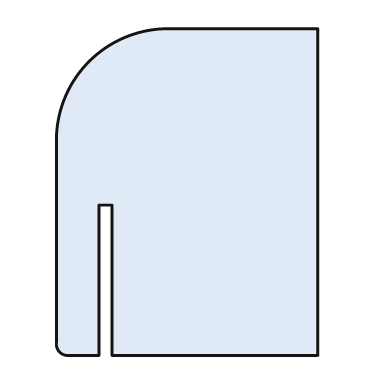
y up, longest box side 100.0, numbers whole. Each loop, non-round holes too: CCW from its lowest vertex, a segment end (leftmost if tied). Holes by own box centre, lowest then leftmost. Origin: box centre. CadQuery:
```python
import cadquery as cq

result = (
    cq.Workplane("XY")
    .moveTo(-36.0, -50.0)
    .lineTo(-27.0, -50.0)
    .lineTo(-27.0, -4.0)
    .lineTo(-23.0, -4.0)
    .lineTo(-23.0, -50.0)
    .lineTo(40.0, -50.0)
    .lineTo(40.0, 50.0)
    .lineTo(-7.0, 50.0)
    .threePointArc((-30.0, 40.0), (-40.0, 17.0))
    .lineTo(-40.0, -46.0)
    .threePointArc((-39.0, -49.0), (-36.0, -50.0))
    .close()
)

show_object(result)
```